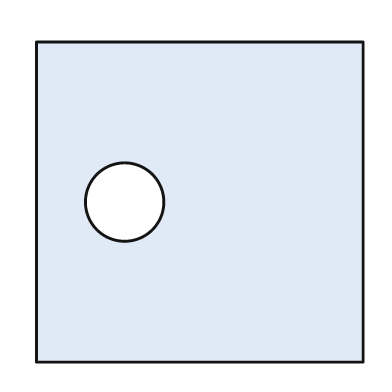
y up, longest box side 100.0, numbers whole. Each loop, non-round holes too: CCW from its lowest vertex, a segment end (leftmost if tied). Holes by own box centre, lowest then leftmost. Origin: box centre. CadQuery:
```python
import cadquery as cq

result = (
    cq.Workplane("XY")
    .moveTo(-50.0, -49.0)
    .lineTo(50.0, -49.0)
    .lineTo(50.0, 49.0)
    .lineTo(-50.0, 49.0)
    .close()
    .moveTo(-23.0, 0.0)
    .circle(12.0)
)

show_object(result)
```